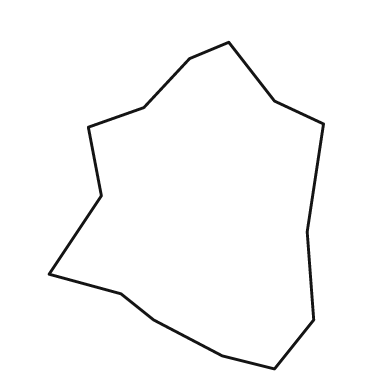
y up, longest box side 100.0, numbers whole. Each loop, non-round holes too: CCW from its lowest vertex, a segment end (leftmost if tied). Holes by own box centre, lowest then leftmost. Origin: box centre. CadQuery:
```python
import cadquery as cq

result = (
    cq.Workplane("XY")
    .moveTo(27.0, -50.0)
    .lineTo(39.0, -35.0)
    .lineTo(37.0, -8.0)
    .lineTo(42.0, 25.0)
    .lineTo(27.0, 32.0)
    .lineTo(13.0, 50.0)
    .lineTo(1.0, 45.0)
    .lineTo(-13.0, 30.0)
    .lineTo(-30.0, 24.0)
    .lineTo(-26.0, 3.0)
    .lineTo(-42.0, -21.0)
    .lineTo(-20.0, -27.0)
    .lineTo(-10.0, -35.0)
    .lineTo(11.0, -46.0)
    .close()
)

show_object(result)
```